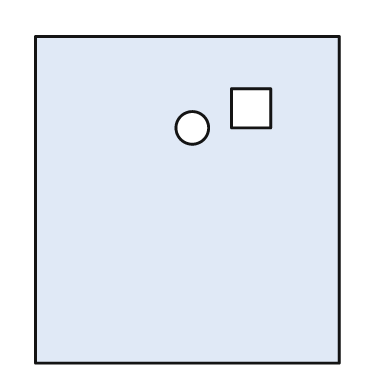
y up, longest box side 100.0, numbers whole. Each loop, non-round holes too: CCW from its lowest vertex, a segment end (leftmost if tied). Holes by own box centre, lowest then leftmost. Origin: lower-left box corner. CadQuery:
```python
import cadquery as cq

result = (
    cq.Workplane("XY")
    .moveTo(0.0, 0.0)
    .lineTo(93.0, 0.0)
    .lineTo(93.0, 100.0)
    .lineTo(0.0, 100.0)
    .close()
    .moveTo(48.0, 72.0)
    .circle(5.0)
    .moveTo(60.0, 72.0)
    .lineTo(72.0, 72.0)
    .lineTo(72.0, 84.0)
    .lineTo(60.0, 84.0)
    .close()
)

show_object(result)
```